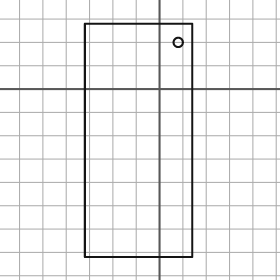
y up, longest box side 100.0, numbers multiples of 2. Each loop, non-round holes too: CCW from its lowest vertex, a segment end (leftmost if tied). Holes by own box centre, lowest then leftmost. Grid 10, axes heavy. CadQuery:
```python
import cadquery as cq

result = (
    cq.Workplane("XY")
    .moveTo(-32.0, -72.0)
    .lineTo(14.0, -72.0)
    .lineTo(14.0, 28.0)
    .lineTo(-32.0, 28.0)
    .close()
    .moveTo(8.0, 20.0)
    .circle(2.0)
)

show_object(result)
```